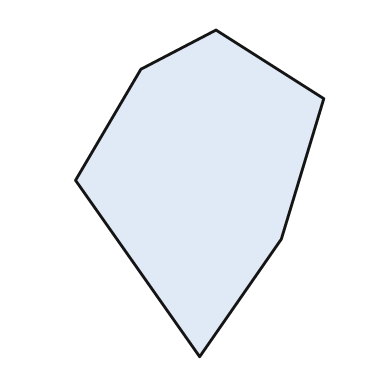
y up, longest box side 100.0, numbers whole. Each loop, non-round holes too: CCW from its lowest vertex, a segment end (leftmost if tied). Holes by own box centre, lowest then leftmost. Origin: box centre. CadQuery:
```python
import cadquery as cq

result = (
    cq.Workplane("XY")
    .moveTo(0.0, -50.0)
    .lineTo(25.0, -14.0)
    .lineTo(38.0, 29.0)
    .lineTo(5.0, 50.0)
    .lineTo(-18.0, 38.0)
    .lineTo(-38.0, 4.0)
    .close()
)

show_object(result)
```